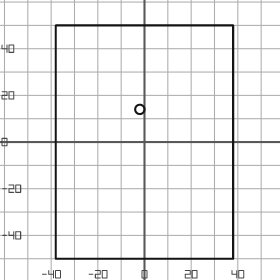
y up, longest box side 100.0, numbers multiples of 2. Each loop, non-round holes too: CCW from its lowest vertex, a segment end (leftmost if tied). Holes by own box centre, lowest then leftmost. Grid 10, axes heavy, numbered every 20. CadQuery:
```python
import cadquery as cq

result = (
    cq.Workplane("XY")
    .moveTo(-38.0, -50.0)
    .lineTo(38.0, -50.0)
    .lineTo(38.0, 50.0)
    .lineTo(-38.0, 50.0)
    .close()
    .moveTo(-2.0, 14.0)
    .circle(2.0)
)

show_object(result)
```